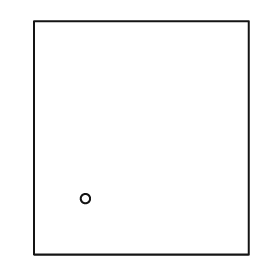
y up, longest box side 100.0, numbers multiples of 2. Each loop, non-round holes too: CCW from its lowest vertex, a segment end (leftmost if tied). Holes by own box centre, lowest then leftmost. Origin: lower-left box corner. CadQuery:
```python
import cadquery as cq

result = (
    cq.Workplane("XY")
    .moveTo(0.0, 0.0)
    .lineTo(92.0, 0.0)
    .lineTo(92.0, 100.0)
    .lineTo(0.0, 100.0)
    .close()
    .moveTo(22.0, 24.0)
    .circle(2.0)
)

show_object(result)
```